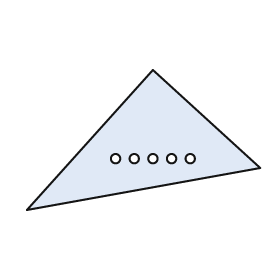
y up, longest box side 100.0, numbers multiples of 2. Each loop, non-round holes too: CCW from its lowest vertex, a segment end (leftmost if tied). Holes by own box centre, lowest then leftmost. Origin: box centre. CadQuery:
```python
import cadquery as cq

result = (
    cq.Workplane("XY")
    .moveTo(-50.0, -30.0)
    .lineTo(50.0, -12.0)
    .lineTo(4.0, 30.0)
    .close()
    .moveTo(-12.0, -8.0)
    .circle(2.0)
    .moveTo(-4.0, -8.0)
    .circle(2.0)
    .moveTo(4.0, -8.0)
    .circle(2.0)
    .moveTo(12.0, -8.0)
    .circle(2.0)
    .moveTo(20.0, -8.0)
    .circle(2.0)
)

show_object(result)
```